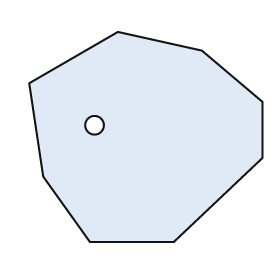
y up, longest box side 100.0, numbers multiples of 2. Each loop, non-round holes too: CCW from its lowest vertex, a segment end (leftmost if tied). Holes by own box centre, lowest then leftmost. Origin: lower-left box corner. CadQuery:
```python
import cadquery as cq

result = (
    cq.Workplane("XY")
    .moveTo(26.0, 0.0)
    .lineTo(62.0, 0.0)
    .lineTo(100.0, 36.0)
    .lineTo(100.0, 60.0)
    .lineTo(74.0, 82.0)
    .lineTo(38.0, 90.0)
    .lineTo(0.0, 68.0)
    .lineTo(6.0, 28.0)
    .close()
    .moveTo(28.0, 50.0)
    .circle(4.0)
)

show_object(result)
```